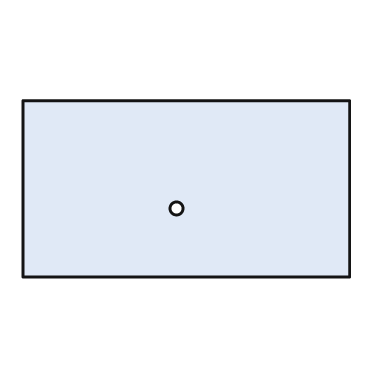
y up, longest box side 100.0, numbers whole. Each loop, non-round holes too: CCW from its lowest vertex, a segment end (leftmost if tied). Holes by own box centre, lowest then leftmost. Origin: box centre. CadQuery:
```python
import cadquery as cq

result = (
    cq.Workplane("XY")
    .moveTo(-50.0, -27.0)
    .lineTo(50.0, -27.0)
    .lineTo(50.0, 27.0)
    .lineTo(-50.0, 27.0)
    .close()
    .moveTo(-3.0, -6.0)
    .circle(2.0)
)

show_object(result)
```